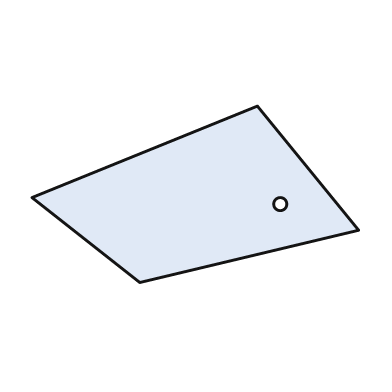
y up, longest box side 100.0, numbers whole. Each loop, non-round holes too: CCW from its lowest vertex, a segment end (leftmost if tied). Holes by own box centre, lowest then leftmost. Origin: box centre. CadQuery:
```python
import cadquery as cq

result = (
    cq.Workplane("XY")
    .moveTo(-17.0, -27.0)
    .lineTo(50.0, -11.0)
    .lineTo(19.0, 27.0)
    .lineTo(-50.0, -1.0)
    .close()
    .moveTo(26.0, -3.0)
    .circle(2.0)
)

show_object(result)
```